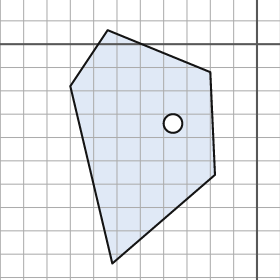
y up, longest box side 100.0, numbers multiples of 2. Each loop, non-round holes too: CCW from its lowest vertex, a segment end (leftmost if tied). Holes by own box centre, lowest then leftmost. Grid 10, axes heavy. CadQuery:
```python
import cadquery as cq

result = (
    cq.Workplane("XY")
    .moveTo(-62.0, -94.0)
    .lineTo(-18.0, -56.0)
    .lineTo(-20.0, -12.0)
    .lineTo(-64.0, 6.0)
    .lineTo(-80.0, -18.0)
    .close()
    .moveTo(-36.0, -34.0)
    .circle(4.0)
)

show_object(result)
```